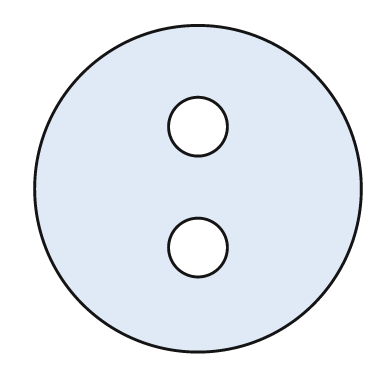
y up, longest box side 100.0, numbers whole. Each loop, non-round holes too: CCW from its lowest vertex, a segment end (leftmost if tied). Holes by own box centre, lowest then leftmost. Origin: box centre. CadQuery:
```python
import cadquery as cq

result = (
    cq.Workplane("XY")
    .moveTo(0.0, 0.0)
    .circle(50.0)
    .moveTo(0.0, -18.0)
    .circle(9.0)
    .moveTo(0.0, 19.0)
    .circle(9.0)
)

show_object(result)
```